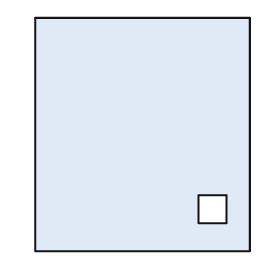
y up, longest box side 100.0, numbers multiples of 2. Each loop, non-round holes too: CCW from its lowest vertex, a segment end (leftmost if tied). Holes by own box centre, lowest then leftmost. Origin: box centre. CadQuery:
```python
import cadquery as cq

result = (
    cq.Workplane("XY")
    .moveTo(-46.0, -50.0)
    .lineTo(46.0, -50.0)
    .lineTo(46.0, 50.0)
    .lineTo(-46.0, 50.0)
    .close()
    .moveTo(24.0, -38.0)
    .lineTo(36.0, -38.0)
    .lineTo(36.0, -26.0)
    .lineTo(24.0, -26.0)
    .close()
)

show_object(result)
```